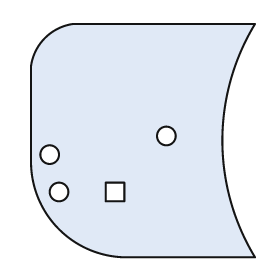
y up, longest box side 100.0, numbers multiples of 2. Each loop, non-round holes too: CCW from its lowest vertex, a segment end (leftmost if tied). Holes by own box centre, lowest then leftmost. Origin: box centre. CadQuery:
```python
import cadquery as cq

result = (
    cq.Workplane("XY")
    .moveTo(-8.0, -50.0)
    .lineTo(48.0, -50.0)
    .threePointArc((34.0, 0.0), (48.0, 50.0))
    .lineTo(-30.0, 50.0)
    .threePointArc((-42.0, 44.0), (-48.0, 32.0))
    .lineTo(-48.0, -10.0)
    .threePointArc((-36.0, -38.0), (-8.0, -50.0))
    .close()
    .moveTo(-36.0, -22.0)
    .circle(4.0)
    .moveTo(-16.0, -26.0)
    .lineTo(-8.0, -26.0)
    .lineTo(-8.0, -18.0)
    .lineTo(-16.0, -18.0)
    .close()
    .moveTo(-40.0, -6.0)
    .circle(4.0)
    .moveTo(10.0, 2.0)
    .circle(4.0)
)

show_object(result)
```